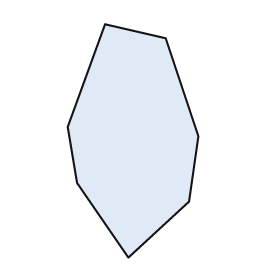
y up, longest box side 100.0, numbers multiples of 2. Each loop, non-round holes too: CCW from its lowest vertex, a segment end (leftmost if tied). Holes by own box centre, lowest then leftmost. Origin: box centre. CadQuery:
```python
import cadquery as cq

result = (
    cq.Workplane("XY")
    .moveTo(-2.0, -50.0)
    .lineTo(24.0, -26.0)
    .lineTo(28.0, 2.0)
    .lineTo(14.0, 44.0)
    .lineTo(-12.0, 50.0)
    .lineTo(-28.0, 6.0)
    .lineTo(-24.0, -18.0)
    .close()
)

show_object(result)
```